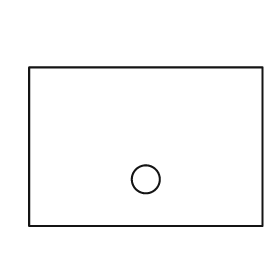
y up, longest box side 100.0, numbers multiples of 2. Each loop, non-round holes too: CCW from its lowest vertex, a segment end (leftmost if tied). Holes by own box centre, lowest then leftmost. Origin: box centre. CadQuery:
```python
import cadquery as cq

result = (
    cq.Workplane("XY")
    .moveTo(-50.0, -34.0)
    .lineTo(50.0, -34.0)
    .lineTo(50.0, 34.0)
    .lineTo(-50.0, 34.0)
    .close()
    .moveTo(0.0, -14.0)
    .circle(6.0)
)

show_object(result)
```